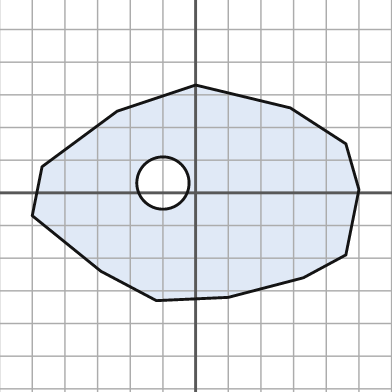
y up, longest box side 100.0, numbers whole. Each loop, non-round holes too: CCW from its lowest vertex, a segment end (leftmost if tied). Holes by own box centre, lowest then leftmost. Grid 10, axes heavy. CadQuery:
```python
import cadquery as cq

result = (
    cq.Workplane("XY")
    .moveTo(-12.0, -33.0)
    .lineTo(10.0, -32.0)
    .lineTo(33.0, -26.0)
    .lineTo(46.0, -19.0)
    .lineTo(50.0, 1.0)
    .lineTo(46.0, 15.0)
    .lineTo(29.0, 26.0)
    .lineTo(0.0, 33.0)
    .lineTo(-24.0, 25.0)
    .lineTo(-47.0, 8.0)
    .lineTo(-50.0, -7.0)
    .lineTo(-29.0, -24.0)
    .close()
    .moveTo(-10.0, 3.0)
    .circle(8.0)
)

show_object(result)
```